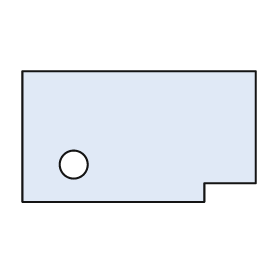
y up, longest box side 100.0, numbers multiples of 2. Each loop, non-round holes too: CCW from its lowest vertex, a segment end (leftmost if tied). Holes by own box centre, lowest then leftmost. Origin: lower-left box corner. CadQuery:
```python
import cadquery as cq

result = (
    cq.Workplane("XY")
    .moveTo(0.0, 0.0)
    .lineTo(78.0, 0.0)
    .lineTo(78.0, 8.0)
    .lineTo(100.0, 8.0)
    .lineTo(100.0, 56.0)
    .lineTo(0.0, 56.0)
    .close()
    .moveTo(22.0, 16.0)
    .circle(6.0)
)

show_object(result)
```